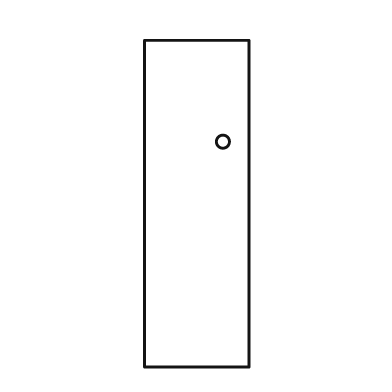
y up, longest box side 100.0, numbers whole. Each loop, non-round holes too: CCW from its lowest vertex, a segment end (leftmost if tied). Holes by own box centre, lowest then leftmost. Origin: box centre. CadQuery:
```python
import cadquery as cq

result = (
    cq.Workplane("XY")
    .moveTo(-16.0, -50.0)
    .lineTo(16.0, -50.0)
    .lineTo(16.0, 50.0)
    .lineTo(-16.0, 50.0)
    .close()
    .moveTo(8.0, 19.0)
    .circle(2.0)
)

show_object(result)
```